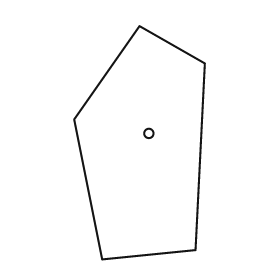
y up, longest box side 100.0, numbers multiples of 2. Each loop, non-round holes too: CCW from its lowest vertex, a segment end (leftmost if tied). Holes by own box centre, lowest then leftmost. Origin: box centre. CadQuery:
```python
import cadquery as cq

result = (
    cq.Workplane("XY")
    .moveTo(-16.0, -50.0)
    .lineTo(24.0, -46.0)
    .lineTo(28.0, 34.0)
    .lineTo(0.0, 50.0)
    .lineTo(-28.0, 10.0)
    .close()
    .moveTo(4.0, 4.0)
    .circle(2.0)
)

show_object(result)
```